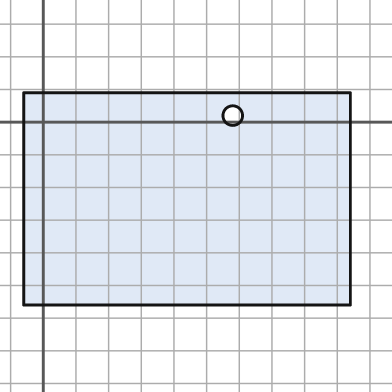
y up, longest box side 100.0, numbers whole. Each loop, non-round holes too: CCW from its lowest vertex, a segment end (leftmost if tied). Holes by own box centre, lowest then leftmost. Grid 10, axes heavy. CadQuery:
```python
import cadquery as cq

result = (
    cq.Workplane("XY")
    .moveTo(-6.0, -56.0)
    .lineTo(94.0, -56.0)
    .lineTo(94.0, 9.0)
    .lineTo(-6.0, 9.0)
    .close()
    .moveTo(58.0, 2.0)
    .circle(3.0)
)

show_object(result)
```